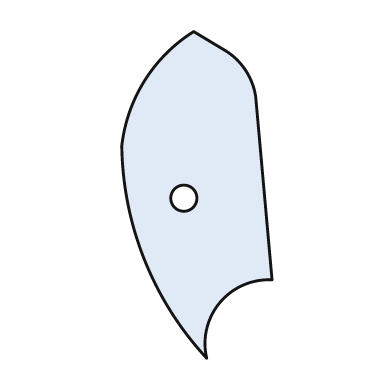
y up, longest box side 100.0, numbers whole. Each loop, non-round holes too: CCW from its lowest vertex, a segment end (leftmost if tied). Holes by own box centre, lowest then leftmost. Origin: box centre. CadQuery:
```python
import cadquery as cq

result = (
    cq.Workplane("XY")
    .moveTo(3.0, -50.0)
    .threePointArc((7.0, -33.0), (23.0, -26.0))
    .lineTo(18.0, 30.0)
    .threePointArc((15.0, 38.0), (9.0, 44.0))
    .lineTo(-1.0, 50.0)
    .threePointArc((-16.0, 35.0), (-23.0, 15.0))
    .threePointArc((-16.0, -20.0), (3.0, -50.0))
    .close()
    .moveTo(-4.0, -1.0)
    .circle(4.0)
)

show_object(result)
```